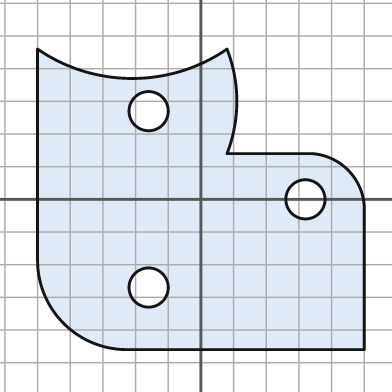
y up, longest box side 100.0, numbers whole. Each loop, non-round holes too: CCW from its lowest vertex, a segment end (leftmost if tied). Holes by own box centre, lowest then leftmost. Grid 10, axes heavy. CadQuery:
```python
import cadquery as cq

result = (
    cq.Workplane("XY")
    .moveTo(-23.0, -46.0)
    .lineTo(50.0, -46.0)
    .lineTo(50.0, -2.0)
    .threePointArc((45.0, 9.0), (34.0, 14.0))
    .lineTo(8.0, 14.0)
    .threePointArc((11.0, 30.0), (8.0, 46.0))
    .threePointArc((-21.0, 37.0), (-50.0, 46.0))
    .lineTo(-50.0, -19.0)
    .threePointArc((-42.0, -38.0), (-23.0, -46.0))
    .close()
    .moveTo(-16.0, -27.0)
    .circle(6.0)
    .moveTo(32.0, 0.0)
    .circle(6.0)
    .moveTo(-16.0, 27.0)
    .circle(6.0)
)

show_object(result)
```